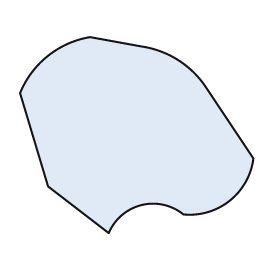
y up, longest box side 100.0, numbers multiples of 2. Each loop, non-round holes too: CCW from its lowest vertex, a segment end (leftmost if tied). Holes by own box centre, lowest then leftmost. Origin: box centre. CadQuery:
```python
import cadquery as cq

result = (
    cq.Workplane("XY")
    .moveTo(-12.0, -42.0)
    .threePointArc((2.0, -30.0), (20.0, -34.0))
    .threePointArc((40.0, -28.0), (50.0, -10.0))
    .lineTo(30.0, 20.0)
    .threePointArc((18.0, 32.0), (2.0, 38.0))
    .lineTo(-20.0, 42.0)
    .threePointArc((-38.0, 34.0), (-50.0, 18.0))
    .lineTo(-38.0, -22.0)
    .close()
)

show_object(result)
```